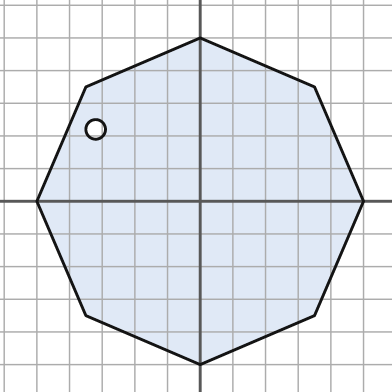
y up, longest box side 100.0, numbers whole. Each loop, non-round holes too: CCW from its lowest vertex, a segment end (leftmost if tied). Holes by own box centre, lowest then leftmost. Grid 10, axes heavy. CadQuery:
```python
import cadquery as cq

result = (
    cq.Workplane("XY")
    .moveTo(0.0, -50.0)
    .lineTo(35.0, -35.0)
    .lineTo(50.0, 0.0)
    .lineTo(35.0, 35.0)
    .lineTo(0.0, 50.0)
    .lineTo(-35.0, 35.0)
    .lineTo(-50.0, 0.0)
    .lineTo(-35.0, -35.0)
    .close()
    .moveTo(-32.0, 22.0)
    .circle(3.0)
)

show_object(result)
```